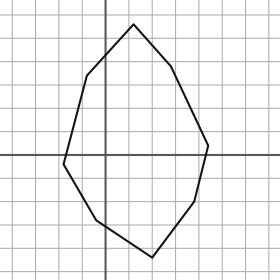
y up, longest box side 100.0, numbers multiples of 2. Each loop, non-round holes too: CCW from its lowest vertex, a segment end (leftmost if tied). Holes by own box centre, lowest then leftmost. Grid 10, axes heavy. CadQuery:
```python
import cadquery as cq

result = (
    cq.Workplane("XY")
    .moveTo(20.0, -44.0)
    .lineTo(38.0, -20.0)
    .lineTo(44.0, 4.0)
    .lineTo(28.0, 38.0)
    .lineTo(12.0, 56.0)
    .lineTo(-8.0, 34.0)
    .lineTo(-18.0, -4.0)
    .lineTo(-4.0, -28.0)
    .close()
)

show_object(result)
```